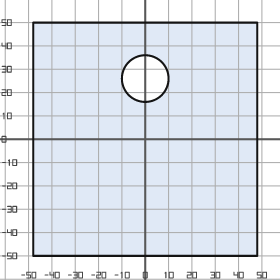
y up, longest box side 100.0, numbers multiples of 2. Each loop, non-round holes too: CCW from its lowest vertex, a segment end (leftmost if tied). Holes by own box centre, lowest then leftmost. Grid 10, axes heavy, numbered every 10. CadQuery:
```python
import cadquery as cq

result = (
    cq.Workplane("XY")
    .moveTo(-48.0, -50.0)
    .lineTo(48.0, -50.0)
    .lineTo(48.0, 50.0)
    .lineTo(-48.0, 50.0)
    .close()
    .moveTo(0.0, 26.0)
    .circle(10.0)
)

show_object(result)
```